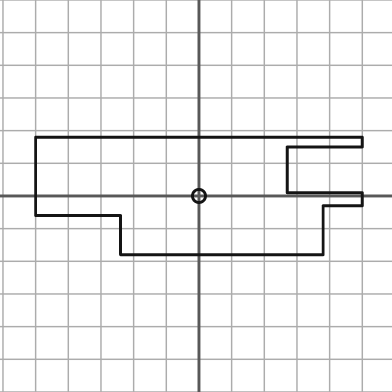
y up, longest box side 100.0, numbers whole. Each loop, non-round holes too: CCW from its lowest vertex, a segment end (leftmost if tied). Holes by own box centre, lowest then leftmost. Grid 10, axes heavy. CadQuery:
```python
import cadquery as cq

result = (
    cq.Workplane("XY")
    .moveTo(-24.0, -18.0)
    .lineTo(38.0, -18.0)
    .lineTo(38.0, -3.0)
    .lineTo(50.0, -3.0)
    .lineTo(50.0, 1.0)
    .lineTo(27.0, 1.0)
    .lineTo(27.0, 15.0)
    .lineTo(50.0, 15.0)
    .lineTo(50.0, 18.0)
    .lineTo(-50.0, 18.0)
    .lineTo(-50.0, -6.0)
    .lineTo(-24.0, -6.0)
    .close()
    .moveTo(0.0, 0.0)
    .circle(2.0)
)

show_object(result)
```